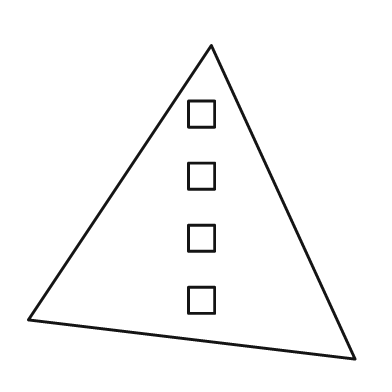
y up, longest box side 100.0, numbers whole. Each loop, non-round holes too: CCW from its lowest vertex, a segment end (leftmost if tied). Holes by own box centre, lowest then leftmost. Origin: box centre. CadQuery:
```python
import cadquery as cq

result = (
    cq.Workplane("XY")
    .moveTo(50.0, -48.0)
    .lineTo(6.0, 48.0)
    .lineTo(-50.0, -36.0)
    .close()
    .moveTo(-1.0, -34.0)
    .lineTo(7.0, -34.0)
    .lineTo(7.0, -26.0)
    .lineTo(-1.0, -26.0)
    .close()
    .moveTo(-1.0, -15.0)
    .lineTo(7.0, -15.0)
    .lineTo(7.0, -7.0)
    .lineTo(-1.0, -7.0)
    .close()
    .moveTo(-1.0, 4.0)
    .lineTo(7.0, 4.0)
    .lineTo(7.0, 12.0)
    .lineTo(-1.0, 12.0)
    .close()
    .moveTo(-1.0, 23.0)
    .lineTo(7.0, 23.0)
    .lineTo(7.0, 31.0)
    .lineTo(-1.0, 31.0)
    .close()
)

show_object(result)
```